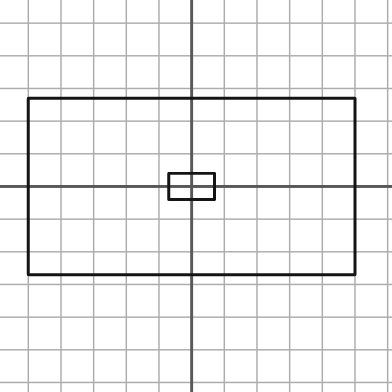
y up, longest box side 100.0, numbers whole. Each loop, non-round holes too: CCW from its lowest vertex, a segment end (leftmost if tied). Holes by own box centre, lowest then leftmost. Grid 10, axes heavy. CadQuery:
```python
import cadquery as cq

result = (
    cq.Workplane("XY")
    .moveTo(-50.0, -27.0)
    .lineTo(50.0, -27.0)
    .lineTo(50.0, 27.0)
    .lineTo(-50.0, 27.0)
    .close()
    .moveTo(-7.0, -4.0)
    .lineTo(7.0, -4.0)
    .lineTo(7.0, 4.0)
    .lineTo(-7.0, 4.0)
    .close()
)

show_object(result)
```